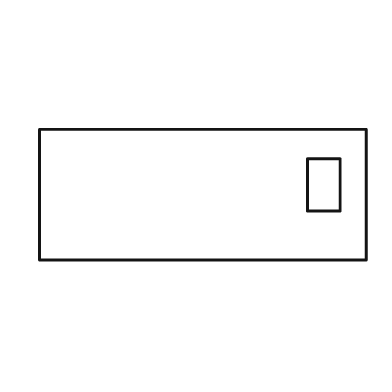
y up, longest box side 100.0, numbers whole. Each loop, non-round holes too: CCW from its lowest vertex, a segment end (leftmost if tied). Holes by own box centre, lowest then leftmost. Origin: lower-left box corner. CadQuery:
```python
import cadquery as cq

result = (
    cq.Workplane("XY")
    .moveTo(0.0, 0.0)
    .lineTo(100.0, 0.0)
    .lineTo(100.0, 40.0)
    .lineTo(0.0, 40.0)
    .close()
    .moveTo(82.0, 15.0)
    .lineTo(92.0, 15.0)
    .lineTo(92.0, 31.0)
    .lineTo(82.0, 31.0)
    .close()
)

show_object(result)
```